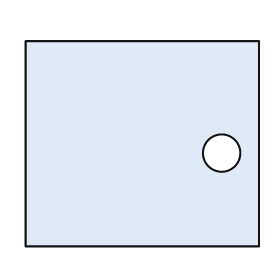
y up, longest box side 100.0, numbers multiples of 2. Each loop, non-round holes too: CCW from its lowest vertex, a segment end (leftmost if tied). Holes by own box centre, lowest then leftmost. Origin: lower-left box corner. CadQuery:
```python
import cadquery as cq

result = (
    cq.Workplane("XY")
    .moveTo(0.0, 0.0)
    .lineTo(100.0, 0.0)
    .lineTo(100.0, 88.0)
    .lineTo(0.0, 88.0)
    .close()
    .moveTo(84.0, 40.0)
    .circle(8.0)
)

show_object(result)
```